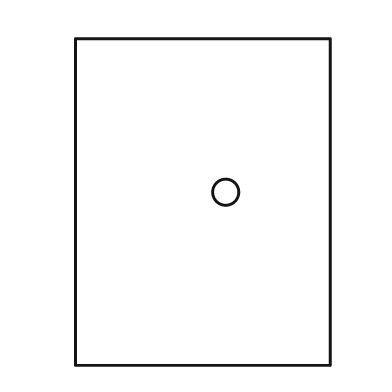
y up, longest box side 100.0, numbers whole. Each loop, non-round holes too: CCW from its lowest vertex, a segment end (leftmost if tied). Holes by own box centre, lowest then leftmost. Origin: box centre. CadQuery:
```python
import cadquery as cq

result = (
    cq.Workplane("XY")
    .moveTo(-39.0, -50.0)
    .lineTo(39.0, -50.0)
    .lineTo(39.0, 50.0)
    .lineTo(-39.0, 50.0)
    .close()
    .moveTo(7.0, 3.0)
    .circle(4.0)
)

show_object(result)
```